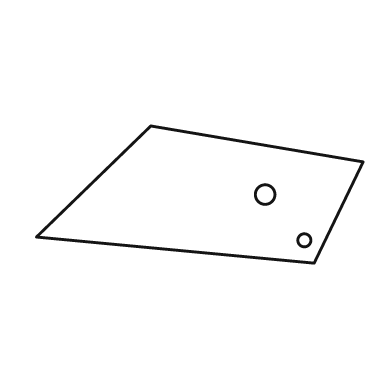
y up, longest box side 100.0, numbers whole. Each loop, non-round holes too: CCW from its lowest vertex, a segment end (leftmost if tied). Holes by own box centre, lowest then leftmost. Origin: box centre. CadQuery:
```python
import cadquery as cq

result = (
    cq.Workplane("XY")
    .moveTo(35.0, -21.0)
    .lineTo(50.0, 10.0)
    .lineTo(-15.0, 21.0)
    .lineTo(-50.0, -13.0)
    .close()
    .moveTo(32.0, -14.0)
    .circle(2.0)
    .moveTo(20.0, 0.0)
    .circle(3.0)
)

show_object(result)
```